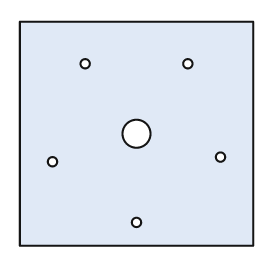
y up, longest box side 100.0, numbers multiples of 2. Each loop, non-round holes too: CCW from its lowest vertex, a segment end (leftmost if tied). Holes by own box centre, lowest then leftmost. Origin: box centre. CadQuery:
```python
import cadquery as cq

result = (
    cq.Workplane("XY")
    .moveTo(-50.0, -48.0)
    .lineTo(50.0, -48.0)
    .lineTo(50.0, 48.0)
    .lineTo(-50.0, 48.0)
    .close()
    .moveTo(0.0, -38.0)
    .circle(2.0)
    .moveTo(-36.0, -12.0)
    .circle(2.0)
    .moveTo(36.0, -10.0)
    .circle(2.0)
    .moveTo(0.0, 0.0)
    .circle(6.0)
    .moveTo(-22.0, 30.0)
    .circle(2.0)
    .moveTo(22.0, 30.0)
    .circle(2.0)
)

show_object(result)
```